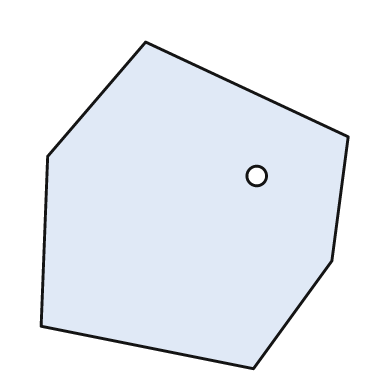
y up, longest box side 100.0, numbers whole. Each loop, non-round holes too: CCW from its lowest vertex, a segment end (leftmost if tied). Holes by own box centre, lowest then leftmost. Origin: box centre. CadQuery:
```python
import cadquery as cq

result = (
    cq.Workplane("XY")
    .moveTo(18.0, -50.0)
    .lineTo(42.0, -17.0)
    .lineTo(47.0, 21.0)
    .lineTo(-15.0, 50.0)
    .lineTo(-45.0, 15.0)
    .lineTo(-47.0, -37.0)
    .close()
    .moveTo(19.0, 9.0)
    .circle(3.0)
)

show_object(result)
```